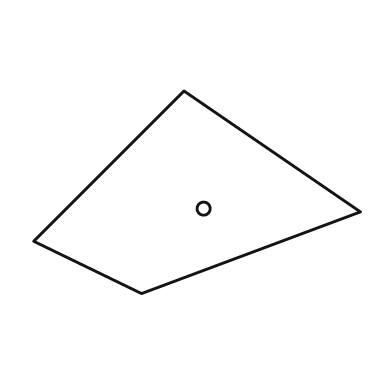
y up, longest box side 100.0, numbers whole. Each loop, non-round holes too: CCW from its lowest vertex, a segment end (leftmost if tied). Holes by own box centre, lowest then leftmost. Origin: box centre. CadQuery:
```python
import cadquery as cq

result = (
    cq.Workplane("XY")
    .moveTo(-17.0, -31.0)
    .lineTo(50.0, -6.0)
    .lineTo(-4.0, 31.0)
    .lineTo(-50.0, -15.0)
    .close()
    .moveTo(2.0, -5.0)
    .circle(2.0)
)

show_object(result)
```